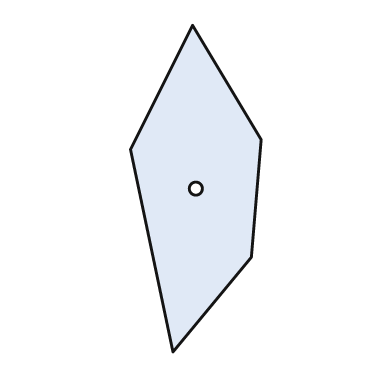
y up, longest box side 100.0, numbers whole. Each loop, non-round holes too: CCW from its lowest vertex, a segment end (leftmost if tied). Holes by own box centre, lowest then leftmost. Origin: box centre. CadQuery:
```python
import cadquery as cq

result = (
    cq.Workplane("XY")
    .moveTo(-7.0, -50.0)
    .lineTo(17.0, -21.0)
    .lineTo(20.0, 15.0)
    .lineTo(-1.0, 50.0)
    .lineTo(-20.0, 12.0)
    .close()
    .moveTo(0.0, 0.0)
    .circle(2.0)
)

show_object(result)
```